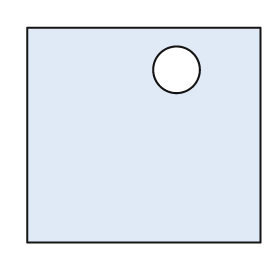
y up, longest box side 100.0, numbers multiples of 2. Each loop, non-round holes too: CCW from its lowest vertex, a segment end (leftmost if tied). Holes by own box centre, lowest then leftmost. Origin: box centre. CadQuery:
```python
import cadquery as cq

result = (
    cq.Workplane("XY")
    .moveTo(-50.0, -46.0)
    .lineTo(50.0, -46.0)
    .lineTo(50.0, 46.0)
    .lineTo(-50.0, 46.0)
    .close()
    .moveTo(14.0, 28.0)
    .circle(10.0)
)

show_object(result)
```